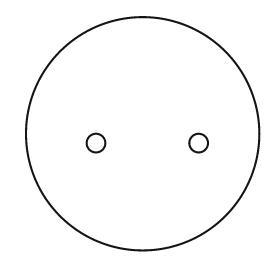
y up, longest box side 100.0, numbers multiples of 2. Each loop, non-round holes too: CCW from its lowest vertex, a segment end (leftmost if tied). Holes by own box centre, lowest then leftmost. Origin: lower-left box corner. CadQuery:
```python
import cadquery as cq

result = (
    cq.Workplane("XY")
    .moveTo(50.0, 50.0)
    .circle(50.0)
    .moveTo(30.0, 46.0)
    .circle(4.0)
    .moveTo(74.0, 46.0)
    .circle(4.0)
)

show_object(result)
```